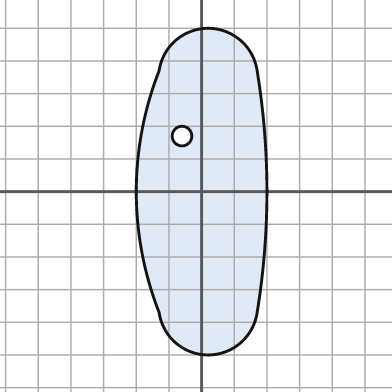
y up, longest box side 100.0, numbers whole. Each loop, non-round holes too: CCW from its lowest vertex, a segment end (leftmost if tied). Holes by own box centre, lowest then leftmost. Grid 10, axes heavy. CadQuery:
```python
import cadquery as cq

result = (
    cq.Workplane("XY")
    .moveTo(-13.0, -37.0)
    .threePointArc((2.0, -50.0), (17.0, -37.0))
    .threePointArc((20.0, 0.0), (17.0, 37.0))
    .threePointArc((2.0, 50.0), (-13.0, 37.0))
    .threePointArc((-20.0, 0.0), (-13.0, -37.0))
    .close()
    .moveTo(-6.0, 17.0)
    .circle(3.0)
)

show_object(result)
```